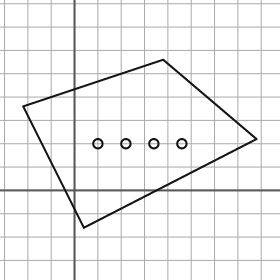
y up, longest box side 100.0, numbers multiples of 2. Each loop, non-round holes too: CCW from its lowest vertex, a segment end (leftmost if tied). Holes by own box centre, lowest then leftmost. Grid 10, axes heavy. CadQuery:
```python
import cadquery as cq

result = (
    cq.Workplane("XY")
    .moveTo(4.0, -16.0)
    .lineTo(78.0, 22.0)
    .lineTo(38.0, 56.0)
    .lineTo(-22.0, 36.0)
    .close()
    .moveTo(10.0, 20.0)
    .circle(2.0)
    .moveTo(22.0, 20.0)
    .circle(2.0)
    .moveTo(34.0, 20.0)
    .circle(2.0)
    .moveTo(46.0, 20.0)
    .circle(2.0)
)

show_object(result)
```